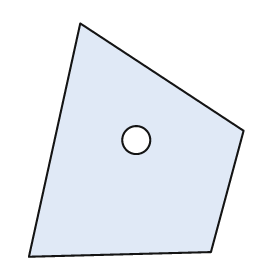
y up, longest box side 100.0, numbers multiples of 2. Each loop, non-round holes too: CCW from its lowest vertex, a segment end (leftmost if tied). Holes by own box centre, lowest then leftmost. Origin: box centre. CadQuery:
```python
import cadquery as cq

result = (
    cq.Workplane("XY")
    .moveTo(-46.0, -50.0)
    .lineTo(32.0, -48.0)
    .lineTo(46.0, 4.0)
    .lineTo(-24.0, 50.0)
    .close()
    .moveTo(0.0, 0.0)
    .circle(6.0)
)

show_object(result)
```